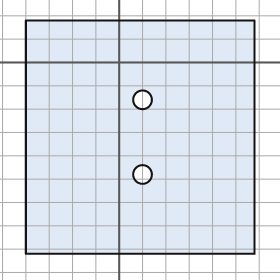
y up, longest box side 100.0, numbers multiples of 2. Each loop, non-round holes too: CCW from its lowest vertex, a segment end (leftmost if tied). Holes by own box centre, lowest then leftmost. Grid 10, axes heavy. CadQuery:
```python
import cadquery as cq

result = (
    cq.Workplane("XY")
    .moveTo(-40.0, -82.0)
    .lineTo(58.0, -82.0)
    .lineTo(58.0, 18.0)
    .lineTo(-40.0, 18.0)
    .close()
    .moveTo(10.0, -48.0)
    .circle(4.0)
    .moveTo(10.0, -16.0)
    .circle(4.0)
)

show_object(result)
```